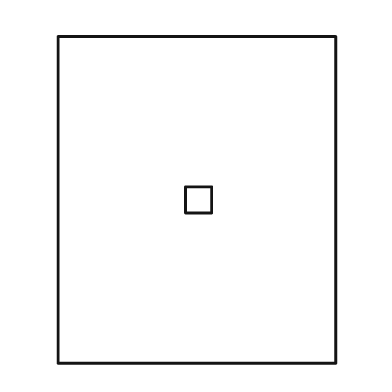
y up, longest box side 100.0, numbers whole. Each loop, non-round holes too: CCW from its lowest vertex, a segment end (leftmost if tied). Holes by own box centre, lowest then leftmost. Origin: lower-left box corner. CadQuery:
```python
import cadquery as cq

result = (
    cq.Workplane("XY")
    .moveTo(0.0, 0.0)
    .lineTo(85.0, 0.0)
    .lineTo(85.0, 100.0)
    .lineTo(0.0, 100.0)
    .close()
    .moveTo(39.0, 46.0)
    .lineTo(47.0, 46.0)
    .lineTo(47.0, 54.0)
    .lineTo(39.0, 54.0)
    .close()
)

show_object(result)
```